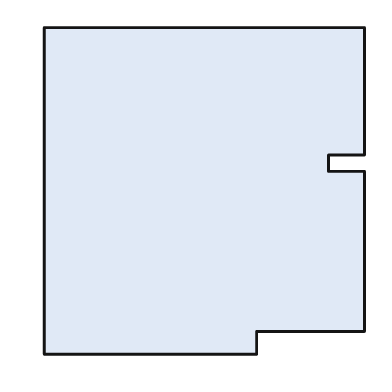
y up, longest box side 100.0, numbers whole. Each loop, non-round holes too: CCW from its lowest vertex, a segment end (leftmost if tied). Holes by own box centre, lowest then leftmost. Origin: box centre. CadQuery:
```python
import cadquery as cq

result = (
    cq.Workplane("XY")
    .moveTo(-49.0, -50.0)
    .lineTo(16.0, -50.0)
    .lineTo(16.0, -43.0)
    .lineTo(49.0, -43.0)
    .lineTo(49.0, 6.0)
    .lineTo(38.0, 6.0)
    .lineTo(38.0, 11.0)
    .lineTo(49.0, 11.0)
    .lineTo(49.0, 50.0)
    .lineTo(-49.0, 50.0)
    .close()
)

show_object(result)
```